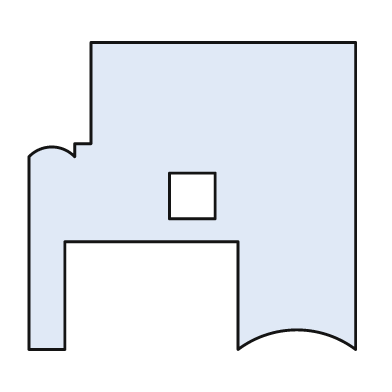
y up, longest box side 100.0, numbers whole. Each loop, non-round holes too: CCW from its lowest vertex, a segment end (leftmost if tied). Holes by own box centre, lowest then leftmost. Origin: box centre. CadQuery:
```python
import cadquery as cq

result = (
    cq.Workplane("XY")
    .moveTo(-50.0, -47.0)
    .lineTo(-39.0, -47.0)
    .lineTo(-39.0, -14.0)
    .lineTo(14.0, -14.0)
    .lineTo(14.0, -47.0)
    .threePointArc((32.0, -41.0), (50.0, -47.0))
    .lineTo(50.0, 47.0)
    .lineTo(-31.0, 47.0)
    .lineTo(-31.0, 16.0)
    .lineTo(-36.0, 16.0)
    .lineTo(-36.0, 12.0)
    .threePointArc((-43.0, 15.0), (-50.0, 12.0))
    .close()
    .moveTo(-7.0, -7.0)
    .lineTo(7.0, -7.0)
    .lineTo(7.0, 7.0)
    .lineTo(-7.0, 7.0)
    .close()
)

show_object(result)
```